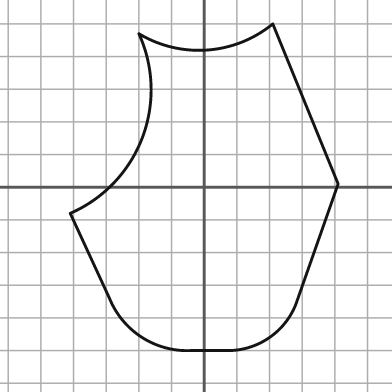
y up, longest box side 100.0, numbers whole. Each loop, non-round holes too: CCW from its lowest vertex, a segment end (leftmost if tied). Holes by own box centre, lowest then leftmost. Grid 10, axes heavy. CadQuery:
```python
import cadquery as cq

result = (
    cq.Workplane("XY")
    .moveTo(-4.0, -50.0)
    .lineTo(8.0, -50.0)
    .threePointArc((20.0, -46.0), (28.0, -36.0))
    .lineTo(41.0, 1.0)
    .lineTo(21.0, 50.0)
    .threePointArc((1.0, 42.0), (-20.0, 47.0))
    .threePointArc((-19.0, 15.0), (-41.0, -8.0))
    .lineTo(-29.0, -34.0)
    .threePointArc((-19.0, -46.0), (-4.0, -50.0))
    .close()
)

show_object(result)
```